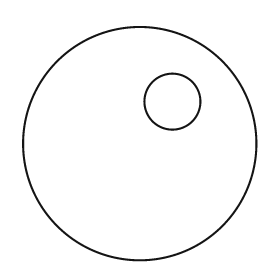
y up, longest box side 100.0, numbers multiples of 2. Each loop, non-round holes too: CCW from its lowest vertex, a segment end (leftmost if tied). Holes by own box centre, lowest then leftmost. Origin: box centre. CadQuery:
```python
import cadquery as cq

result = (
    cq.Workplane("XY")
    .moveTo(0.0, 0.0)
    .circle(50.0)
    .moveTo(14.0, 18.0)
    .circle(12.0)
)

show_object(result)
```